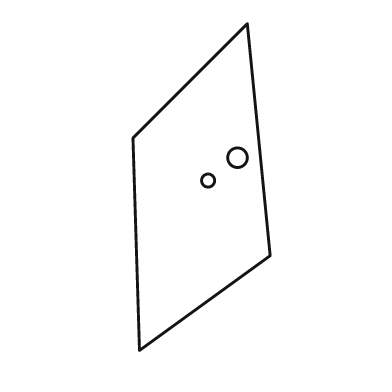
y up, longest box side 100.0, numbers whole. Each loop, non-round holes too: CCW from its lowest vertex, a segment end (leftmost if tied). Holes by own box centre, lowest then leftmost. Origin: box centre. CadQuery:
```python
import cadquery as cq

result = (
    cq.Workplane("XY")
    .moveTo(-19.0, -50.0)
    .lineTo(21.0, -21.0)
    .lineTo(14.0, 50.0)
    .lineTo(-21.0, 15.0)
    .close()
    .moveTo(2.0, 2.0)
    .circle(2.0)
    .moveTo(11.0, 9.0)
    .circle(3.0)
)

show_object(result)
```